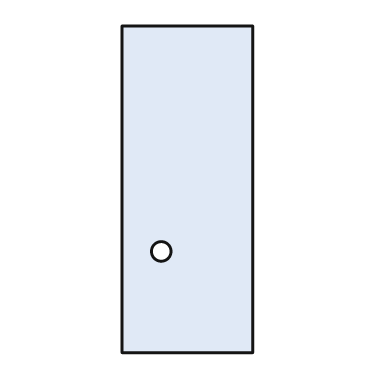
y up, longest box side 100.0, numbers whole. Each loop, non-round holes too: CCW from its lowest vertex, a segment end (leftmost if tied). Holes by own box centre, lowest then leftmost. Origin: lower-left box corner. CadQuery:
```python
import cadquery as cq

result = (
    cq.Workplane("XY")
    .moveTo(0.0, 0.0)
    .lineTo(40.0, 0.0)
    .lineTo(40.0, 100.0)
    .lineTo(0.0, 100.0)
    .close()
    .moveTo(12.0, 31.0)
    .circle(3.0)
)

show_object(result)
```